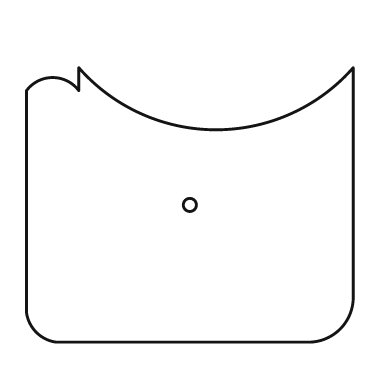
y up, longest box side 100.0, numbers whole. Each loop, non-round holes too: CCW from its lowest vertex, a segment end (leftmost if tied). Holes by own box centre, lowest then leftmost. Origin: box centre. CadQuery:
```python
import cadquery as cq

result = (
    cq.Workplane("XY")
    .moveTo(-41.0, -42.0)
    .lineTo(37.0, -42.0)
    .threePointArc((46.0, -38.0), (50.0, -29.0))
    .lineTo(50.0, 42.0)
    .threePointArc((8.0, 23.0), (-34.0, 42.0))
    .lineTo(-34.0, 35.0)
    .threePointArc((-42.0, 39.0), (-50.0, 35.0))
    .lineTo(-50.0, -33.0)
    .threePointArc((-47.0, -39.0), (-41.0, -42.0))
    .close()
    .moveTo(0.0, 0.0)
    .circle(2.0)
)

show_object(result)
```